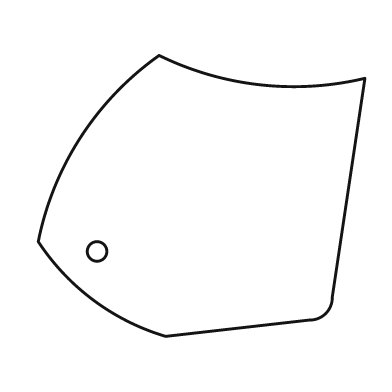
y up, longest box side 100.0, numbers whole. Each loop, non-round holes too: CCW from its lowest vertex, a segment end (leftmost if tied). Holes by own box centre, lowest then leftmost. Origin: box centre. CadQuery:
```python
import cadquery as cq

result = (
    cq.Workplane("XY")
    .moveTo(-11.0, -43.0)
    .lineTo(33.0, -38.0)
    .threePointArc((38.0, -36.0), (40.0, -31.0))
    .lineTo(50.0, 36.0)
    .threePointArc((18.0, 34.0), (-13.0, 43.0))
    .threePointArc((-37.0, 18.0), (-50.0, -14.0))
    .threePointArc((-33.0, -32.0), (-11.0, -43.0))
    .close()
    .moveTo(-32.0, -17.0)
    .circle(3.0)
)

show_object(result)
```